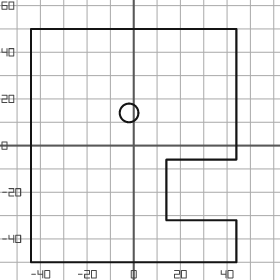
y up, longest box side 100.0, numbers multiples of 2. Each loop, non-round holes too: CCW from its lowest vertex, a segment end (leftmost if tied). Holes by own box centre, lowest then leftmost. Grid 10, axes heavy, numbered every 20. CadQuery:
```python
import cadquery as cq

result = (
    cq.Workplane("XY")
    .moveTo(-44.0, -50.0)
    .lineTo(44.0, -50.0)
    .lineTo(44.0, -32.0)
    .lineTo(14.0, -32.0)
    .lineTo(14.0, -6.0)
    .lineTo(44.0, -6.0)
    .lineTo(44.0, 50.0)
    .lineTo(-44.0, 50.0)
    .close()
    .moveTo(-2.0, 14.0)
    .circle(4.0)
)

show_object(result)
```